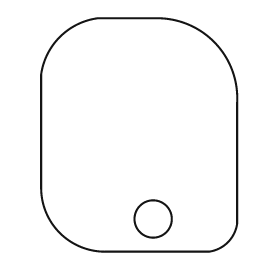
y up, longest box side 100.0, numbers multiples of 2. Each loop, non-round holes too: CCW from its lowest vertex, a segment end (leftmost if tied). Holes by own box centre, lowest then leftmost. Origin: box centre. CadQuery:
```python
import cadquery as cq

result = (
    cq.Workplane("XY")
    .moveTo(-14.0, -50.0)
    .lineTo(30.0, -50.0)
    .threePointArc((38.0, -46.0), (42.0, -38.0))
    .lineTo(42.0, 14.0)
    .threePointArc((32.0, 40.0), (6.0, 50.0))
    .lineTo(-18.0, 50.0)
    .threePointArc((-34.0, 42.0), (-42.0, 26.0))
    .lineTo(-42.0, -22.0)
    .threePointArc((-34.0, -42.0), (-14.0, -50.0))
    .close()
    .moveTo(6.0, -36.0)
    .circle(8.0)
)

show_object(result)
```